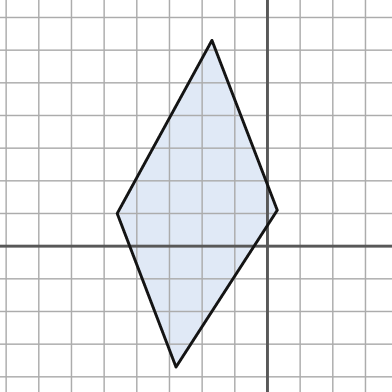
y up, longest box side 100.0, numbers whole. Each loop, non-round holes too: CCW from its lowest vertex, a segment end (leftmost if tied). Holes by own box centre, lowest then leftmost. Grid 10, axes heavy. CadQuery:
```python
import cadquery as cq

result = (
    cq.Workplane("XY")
    .moveTo(-28.0, -37.0)
    .lineTo(3.0, 11.0)
    .lineTo(-17.0, 63.0)
    .lineTo(-46.0, 10.0)
    .close()
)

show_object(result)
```